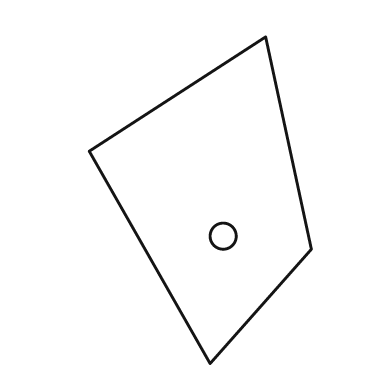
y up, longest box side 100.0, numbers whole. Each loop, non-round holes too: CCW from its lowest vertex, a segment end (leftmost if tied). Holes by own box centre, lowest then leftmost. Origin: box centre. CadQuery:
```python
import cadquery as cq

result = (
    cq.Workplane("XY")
    .moveTo(3.0, -50.0)
    .lineTo(34.0, -15.0)
    .lineTo(20.0, 50.0)
    .lineTo(-34.0, 15.0)
    .close()
    .moveTo(7.0, -11.0)
    .circle(4.0)
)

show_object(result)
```